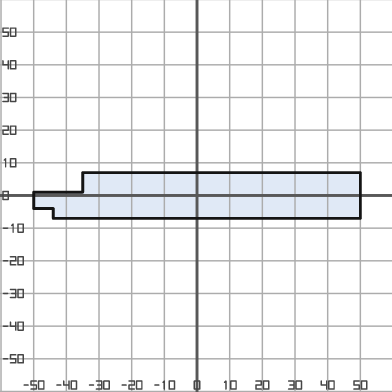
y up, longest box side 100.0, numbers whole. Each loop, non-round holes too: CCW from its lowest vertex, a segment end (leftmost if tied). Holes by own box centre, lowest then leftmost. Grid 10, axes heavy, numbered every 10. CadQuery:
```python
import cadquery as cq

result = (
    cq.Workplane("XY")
    .moveTo(-44.0, -7.0)
    .lineTo(50.0, -7.0)
    .lineTo(50.0, 7.0)
    .lineTo(-35.0, 7.0)
    .lineTo(-35.0, 1.0)
    .lineTo(-50.0, 1.0)
    .lineTo(-50.0, -4.0)
    .lineTo(-44.0, -4.0)
    .close()
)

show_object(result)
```